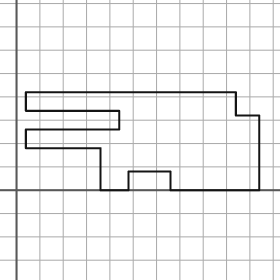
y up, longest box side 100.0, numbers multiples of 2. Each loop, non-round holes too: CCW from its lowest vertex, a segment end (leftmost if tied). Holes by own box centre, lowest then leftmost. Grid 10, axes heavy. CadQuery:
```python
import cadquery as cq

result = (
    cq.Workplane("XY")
    .moveTo(36.0, 0.0)
    .lineTo(48.0, 0.0)
    .lineTo(48.0, 8.0)
    .lineTo(66.0, 8.0)
    .lineTo(66.0, 0.0)
    .lineTo(104.0, 0.0)
    .lineTo(104.0, 32.0)
    .lineTo(94.0, 32.0)
    .lineTo(94.0, 42.0)
    .lineTo(4.0, 42.0)
    .lineTo(4.0, 34.0)
    .lineTo(44.0, 34.0)
    .lineTo(44.0, 26.0)
    .lineTo(4.0, 26.0)
    .lineTo(4.0, 18.0)
    .lineTo(36.0, 18.0)
    .close()
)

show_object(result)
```